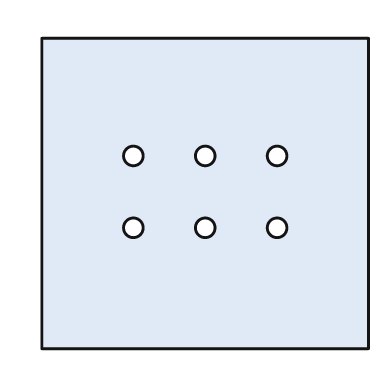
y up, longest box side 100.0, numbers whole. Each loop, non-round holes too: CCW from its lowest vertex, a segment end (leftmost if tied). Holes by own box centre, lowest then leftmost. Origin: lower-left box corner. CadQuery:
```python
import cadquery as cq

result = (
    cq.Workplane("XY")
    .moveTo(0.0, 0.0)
    .lineTo(100.0, 0.0)
    .lineTo(100.0, 95.0)
    .lineTo(0.0, 95.0)
    .close()
    .moveTo(28.0, 37.0)
    .circle(3.0)
    .moveTo(50.0, 37.0)
    .circle(3.0)
    .moveTo(72.0, 37.0)
    .circle(3.0)
    .moveTo(28.0, 59.0)
    .circle(3.0)
    .moveTo(50.0, 59.0)
    .circle(3.0)
    .moveTo(72.0, 59.0)
    .circle(3.0)
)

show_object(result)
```